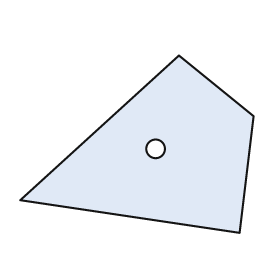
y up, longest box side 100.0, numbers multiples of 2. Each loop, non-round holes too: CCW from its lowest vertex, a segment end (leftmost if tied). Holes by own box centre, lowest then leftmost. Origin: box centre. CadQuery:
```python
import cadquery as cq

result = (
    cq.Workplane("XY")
    .moveTo(44.0, -38.0)
    .lineTo(50.0, 12.0)
    .lineTo(18.0, 38.0)
    .lineTo(-50.0, -24.0)
    .close()
    .moveTo(8.0, -2.0)
    .circle(4.0)
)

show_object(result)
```